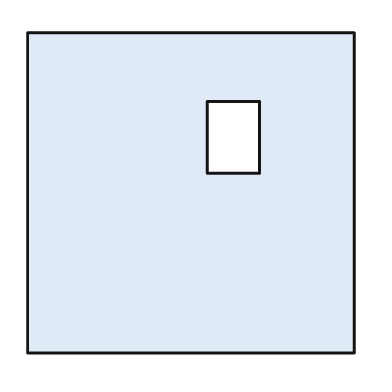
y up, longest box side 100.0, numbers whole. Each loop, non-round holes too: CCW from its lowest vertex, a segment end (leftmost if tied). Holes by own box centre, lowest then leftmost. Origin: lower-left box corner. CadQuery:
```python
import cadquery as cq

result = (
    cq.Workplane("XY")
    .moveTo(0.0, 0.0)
    .lineTo(100.0, 0.0)
    .lineTo(100.0, 98.0)
    .lineTo(0.0, 98.0)
    .close()
    .moveTo(55.0, 55.0)
    .lineTo(71.0, 55.0)
    .lineTo(71.0, 77.0)
    .lineTo(55.0, 77.0)
    .close()
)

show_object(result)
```